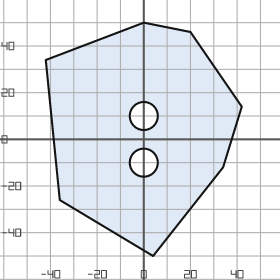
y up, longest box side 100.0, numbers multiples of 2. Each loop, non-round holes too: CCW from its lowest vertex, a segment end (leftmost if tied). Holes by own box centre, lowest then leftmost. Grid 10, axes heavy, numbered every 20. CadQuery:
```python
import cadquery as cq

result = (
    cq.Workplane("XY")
    .moveTo(4.0, -50.0)
    .lineTo(34.0, -12.0)
    .lineTo(42.0, 14.0)
    .lineTo(20.0, 46.0)
    .lineTo(0.0, 50.0)
    .lineTo(-42.0, 34.0)
    .lineTo(-36.0, -26.0)
    .close()
    .moveTo(0.0, -10.0)
    .circle(6.0)
    .moveTo(0.0, 10.0)
    .circle(6.0)
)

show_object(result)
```